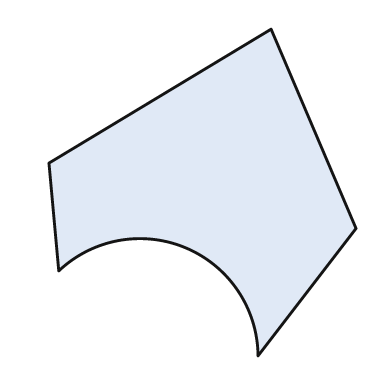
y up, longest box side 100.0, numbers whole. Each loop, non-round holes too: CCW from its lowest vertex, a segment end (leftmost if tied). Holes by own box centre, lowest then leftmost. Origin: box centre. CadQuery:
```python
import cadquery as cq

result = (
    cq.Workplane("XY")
    .moveTo(17.0, -50.0)
    .lineTo(47.0, -11.0)
    .lineTo(21.0, 50.0)
    .lineTo(-47.0, 9.0)
    .lineTo(-44.0, -24.0)
    .threePointArc((-5.0, -17.0), (17.0, -50.0))
    .close()
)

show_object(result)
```